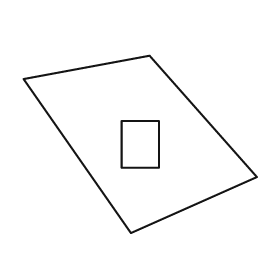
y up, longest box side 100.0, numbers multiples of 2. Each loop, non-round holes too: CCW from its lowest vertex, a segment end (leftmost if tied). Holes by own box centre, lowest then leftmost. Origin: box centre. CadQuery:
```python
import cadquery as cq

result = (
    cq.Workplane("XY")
    .moveTo(-4.0, -38.0)
    .lineTo(50.0, -14.0)
    .lineTo(4.0, 38.0)
    .lineTo(-50.0, 28.0)
    .close()
    .moveTo(-8.0, -10.0)
    .lineTo(8.0, -10.0)
    .lineTo(8.0, 10.0)
    .lineTo(-8.0, 10.0)
    .close()
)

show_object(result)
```